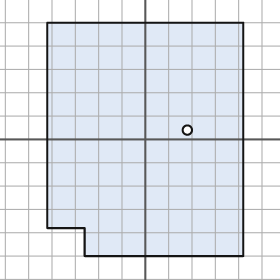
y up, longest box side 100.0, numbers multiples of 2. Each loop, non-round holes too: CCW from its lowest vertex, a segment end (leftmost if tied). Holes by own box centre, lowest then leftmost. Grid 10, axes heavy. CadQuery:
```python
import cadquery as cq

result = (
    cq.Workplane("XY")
    .moveTo(-26.0, -50.0)
    .lineTo(42.0, -50.0)
    .lineTo(42.0, 50.0)
    .lineTo(-42.0, 50.0)
    .lineTo(-42.0, -38.0)
    .lineTo(-26.0, -38.0)
    .close()
    .moveTo(18.0, 4.0)
    .circle(2.0)
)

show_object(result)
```